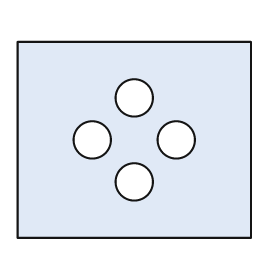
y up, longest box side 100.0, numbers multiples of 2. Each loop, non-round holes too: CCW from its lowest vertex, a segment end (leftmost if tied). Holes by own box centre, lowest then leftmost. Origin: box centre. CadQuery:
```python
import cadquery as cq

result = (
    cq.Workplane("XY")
    .moveTo(-50.0, -42.0)
    .lineTo(50.0, -42.0)
    .lineTo(50.0, 42.0)
    .lineTo(-50.0, 42.0)
    .close()
    .moveTo(0.0, -18.0)
    .circle(8.0)
    .moveTo(-18.0, 0.0)
    .circle(8.0)
    .moveTo(18.0, 0.0)
    .circle(8.0)
    .moveTo(0.0, 18.0)
    .circle(8.0)
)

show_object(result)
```